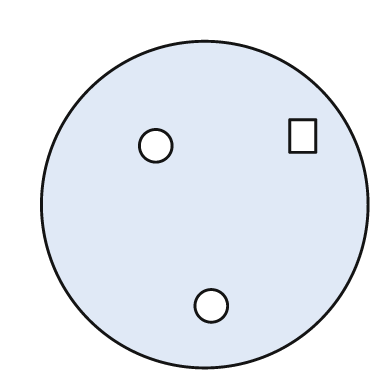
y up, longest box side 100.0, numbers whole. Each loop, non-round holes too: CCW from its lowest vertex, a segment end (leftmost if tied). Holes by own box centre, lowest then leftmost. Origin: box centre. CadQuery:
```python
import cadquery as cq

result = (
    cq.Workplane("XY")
    .moveTo(0.0, 0.0)
    .circle(50.0)
    .moveTo(2.0, -31.0)
    .circle(5.0)
    .moveTo(-15.0, 18.0)
    .circle(5.0)
    .moveTo(26.0, 16.0)
    .lineTo(34.0, 16.0)
    .lineTo(34.0, 26.0)
    .lineTo(26.0, 26.0)
    .close()
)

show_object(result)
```